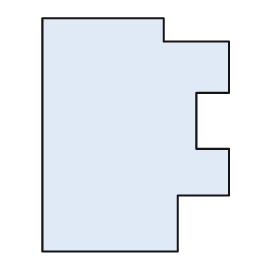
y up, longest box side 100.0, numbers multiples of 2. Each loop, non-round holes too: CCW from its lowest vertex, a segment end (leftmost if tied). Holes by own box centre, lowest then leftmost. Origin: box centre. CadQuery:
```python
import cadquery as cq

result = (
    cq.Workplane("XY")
    .moveTo(-40.0, -50.0)
    .lineTo(18.0, -50.0)
    .lineTo(18.0, -26.0)
    .lineTo(40.0, -26.0)
    .lineTo(40.0, -6.0)
    .lineTo(26.0, -6.0)
    .lineTo(26.0, 18.0)
    .lineTo(40.0, 18.0)
    .lineTo(40.0, 40.0)
    .lineTo(12.0, 40.0)
    .lineTo(12.0, 50.0)
    .lineTo(-40.0, 50.0)
    .close()
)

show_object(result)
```